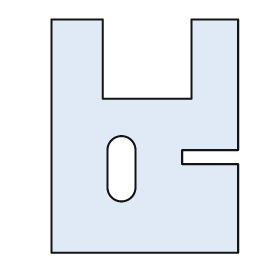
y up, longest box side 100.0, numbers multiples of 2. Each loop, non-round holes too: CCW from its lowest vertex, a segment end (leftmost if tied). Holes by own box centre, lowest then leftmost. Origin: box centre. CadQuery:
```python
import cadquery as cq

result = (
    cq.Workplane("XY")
    .moveTo(-40.0, -50.0)
    .lineTo(40.0, -50.0)
    .lineTo(40.0, -12.0)
    .lineTo(16.0, -12.0)
    .lineTo(16.0, -6.0)
    .lineTo(40.0, -6.0)
    .lineTo(40.0, 50.0)
    .lineTo(20.0, 50.0)
    .lineTo(20.0, 16.0)
    .lineTo(-18.0, 16.0)
    .lineTo(-18.0, 50.0)
    .lineTo(-40.0, 50.0)
    .close()
    .moveTo(-16.0, -22.0)
    .threePointArc((-10.0, -28.0), (-4.0, -22.0))
    .lineTo(-4.0, -6.0)
    .threePointArc((-10.0, 0.0), (-16.0, -6.0))
    .close()
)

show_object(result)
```